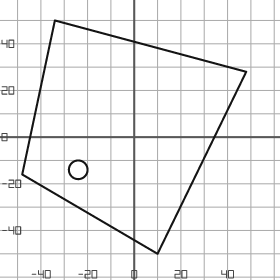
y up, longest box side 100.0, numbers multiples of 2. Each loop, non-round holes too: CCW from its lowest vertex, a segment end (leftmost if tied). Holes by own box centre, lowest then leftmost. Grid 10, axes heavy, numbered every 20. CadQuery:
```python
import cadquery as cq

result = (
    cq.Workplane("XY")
    .moveTo(10.0, -50.0)
    .lineTo(48.0, 28.0)
    .lineTo(-34.0, 50.0)
    .lineTo(-48.0, -16.0)
    .close()
    .moveTo(-24.0, -14.0)
    .circle(4.0)
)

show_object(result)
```